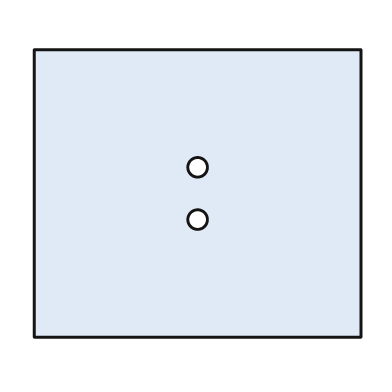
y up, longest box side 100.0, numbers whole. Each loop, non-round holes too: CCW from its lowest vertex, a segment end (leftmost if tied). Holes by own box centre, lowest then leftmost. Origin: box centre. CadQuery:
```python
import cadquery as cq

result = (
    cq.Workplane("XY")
    .moveTo(-50.0, -44.0)
    .lineTo(50.0, -44.0)
    .lineTo(50.0, 44.0)
    .lineTo(-50.0, 44.0)
    .close()
    .moveTo(0.0, -8.0)
    .circle(3.0)
    .moveTo(0.0, 8.0)
    .circle(3.0)
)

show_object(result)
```